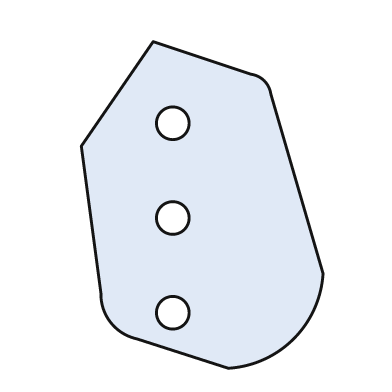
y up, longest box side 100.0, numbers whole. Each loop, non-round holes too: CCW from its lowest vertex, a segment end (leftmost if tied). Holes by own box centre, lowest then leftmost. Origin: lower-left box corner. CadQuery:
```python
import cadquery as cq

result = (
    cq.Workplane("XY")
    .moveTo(45.0, 0.0)
    .threePointArc((65.0, 9.0), (74.0, 29.0))
    .lineTo(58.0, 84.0)
    .threePointArc((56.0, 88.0), (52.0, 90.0))
    .lineTo(22.0, 100.0)
    .lineTo(0.0, 68.0)
    .lineTo(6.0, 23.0)
    .threePointArc((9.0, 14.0), (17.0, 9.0))
    .close()
    .moveTo(28.0, 17.0)
    .circle(5.0)
    .moveTo(28.0, 46.0)
    .circle(5.0)
    .moveTo(28.0, 75.0)
    .circle(5.0)
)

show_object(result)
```